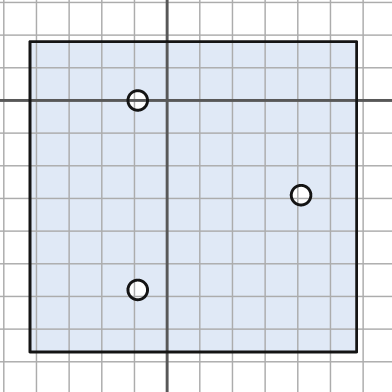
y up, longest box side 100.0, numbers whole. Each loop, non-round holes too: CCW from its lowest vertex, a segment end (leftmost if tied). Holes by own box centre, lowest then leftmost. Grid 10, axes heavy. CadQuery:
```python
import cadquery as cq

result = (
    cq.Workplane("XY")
    .moveTo(-42.0, -77.0)
    .lineTo(58.0, -77.0)
    .lineTo(58.0, 18.0)
    .lineTo(-42.0, 18.0)
    .close()
    .moveTo(-9.0, -58.0)
    .circle(3.0)
    .moveTo(41.0, -29.0)
    .circle(3.0)
    .moveTo(-9.0, 0.0)
    .circle(3.0)
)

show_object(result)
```